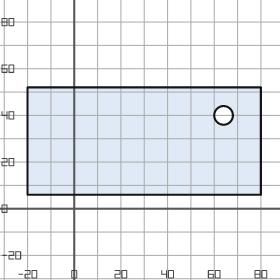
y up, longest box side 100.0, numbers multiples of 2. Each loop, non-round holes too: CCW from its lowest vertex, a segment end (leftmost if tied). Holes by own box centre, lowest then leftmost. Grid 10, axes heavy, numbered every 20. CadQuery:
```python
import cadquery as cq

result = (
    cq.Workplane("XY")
    .moveTo(-20.0, 6.0)
    .lineTo(80.0, 6.0)
    .lineTo(80.0, 52.0)
    .lineTo(-20.0, 52.0)
    .close()
    .moveTo(64.0, 40.0)
    .circle(4.0)
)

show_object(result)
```